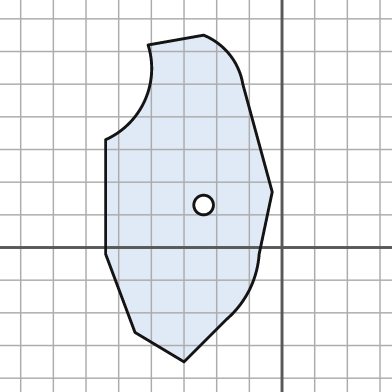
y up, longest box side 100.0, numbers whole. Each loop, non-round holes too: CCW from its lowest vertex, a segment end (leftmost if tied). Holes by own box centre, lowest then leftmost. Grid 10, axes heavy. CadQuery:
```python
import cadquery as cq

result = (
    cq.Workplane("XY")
    .moveTo(-30.0, -35.0)
    .lineTo(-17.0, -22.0)
    .threePointArc((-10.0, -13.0), (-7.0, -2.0))
    .lineTo(-3.0, 17.0)
    .lineTo(-12.0, 50.0)
    .threePointArc((-16.0, 59.0), (-24.0, 65.0))
    .lineTo(-41.0, 62.0)
    .threePointArc((-42.0, 45.0), (-54.0, 33.0))
    .lineTo(-54.0, -2.0)
    .lineTo(-45.0, -26.0)
    .close()
    .moveTo(-24.0, 13.0)
    .circle(3.0)
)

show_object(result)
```